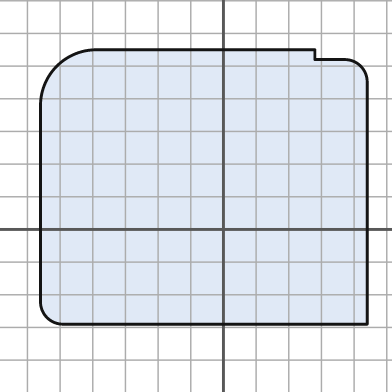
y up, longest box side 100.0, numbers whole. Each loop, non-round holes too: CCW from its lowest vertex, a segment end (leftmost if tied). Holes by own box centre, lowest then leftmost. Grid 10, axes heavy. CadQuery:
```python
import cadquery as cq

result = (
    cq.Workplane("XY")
    .moveTo(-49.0, -29.0)
    .lineTo(44.0, -29.0)
    .lineTo(44.0, 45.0)
    .threePointArc((42.0, 50.0), (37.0, 52.0))
    .lineTo(28.0, 52.0)
    .lineTo(28.0, 55.0)
    .lineTo(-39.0, 55.0)
    .threePointArc((-51.0, 50.0), (-56.0, 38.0))
    .lineTo(-56.0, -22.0)
    .threePointArc((-54.0, -27.0), (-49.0, -29.0))
    .close()
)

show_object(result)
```